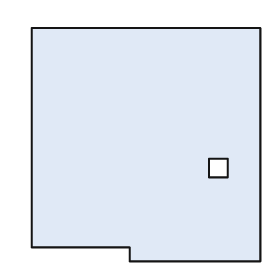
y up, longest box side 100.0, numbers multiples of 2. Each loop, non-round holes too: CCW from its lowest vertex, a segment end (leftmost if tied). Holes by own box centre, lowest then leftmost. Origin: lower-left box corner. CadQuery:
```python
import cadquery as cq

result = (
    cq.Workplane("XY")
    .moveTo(42.0, 0.0)
    .lineTo(98.0, 0.0)
    .lineTo(98.0, 100.0)
    .lineTo(0.0, 100.0)
    .lineTo(0.0, 6.0)
    .lineTo(42.0, 6.0)
    .close()
    .moveTo(76.0, 36.0)
    .lineTo(84.0, 36.0)
    .lineTo(84.0, 44.0)
    .lineTo(76.0, 44.0)
    .close()
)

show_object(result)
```